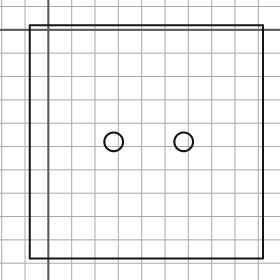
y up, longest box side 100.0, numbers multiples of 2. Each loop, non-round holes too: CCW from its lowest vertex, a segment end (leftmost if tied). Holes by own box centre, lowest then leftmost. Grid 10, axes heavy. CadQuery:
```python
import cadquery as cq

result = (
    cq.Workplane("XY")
    .moveTo(-8.0, -98.0)
    .lineTo(92.0, -98.0)
    .lineTo(92.0, 2.0)
    .lineTo(-8.0, 2.0)
    .close()
    .moveTo(28.0, -48.0)
    .circle(4.0)
    .moveTo(58.0, -48.0)
    .circle(4.0)
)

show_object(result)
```